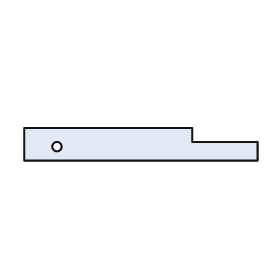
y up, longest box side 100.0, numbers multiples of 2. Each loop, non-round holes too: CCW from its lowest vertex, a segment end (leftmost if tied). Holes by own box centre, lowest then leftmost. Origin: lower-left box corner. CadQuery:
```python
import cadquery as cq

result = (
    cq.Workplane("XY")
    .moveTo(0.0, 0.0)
    .lineTo(100.0, 0.0)
    .lineTo(100.0, 8.0)
    .lineTo(72.0, 8.0)
    .lineTo(72.0, 14.0)
    .lineTo(0.0, 14.0)
    .close()
    .moveTo(14.0, 6.0)
    .circle(2.0)
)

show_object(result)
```